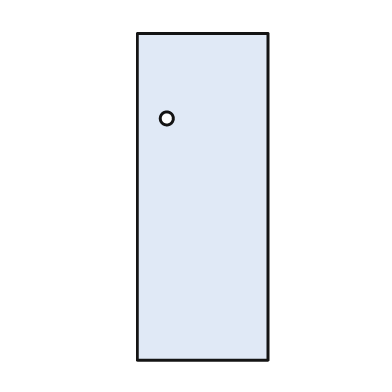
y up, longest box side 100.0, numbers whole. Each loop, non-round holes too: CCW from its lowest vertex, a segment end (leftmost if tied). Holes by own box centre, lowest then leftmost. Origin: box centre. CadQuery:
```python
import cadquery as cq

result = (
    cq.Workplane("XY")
    .moveTo(-20.0, -50.0)
    .lineTo(20.0, -50.0)
    .lineTo(20.0, 50.0)
    .lineTo(-20.0, 50.0)
    .close()
    .moveTo(-11.0, 24.0)
    .circle(2.0)
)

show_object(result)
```